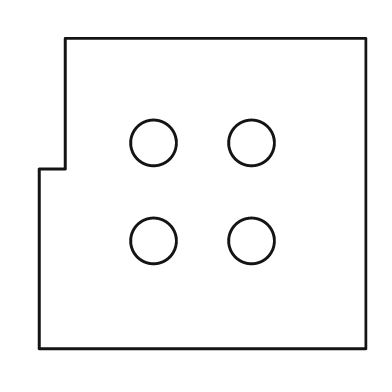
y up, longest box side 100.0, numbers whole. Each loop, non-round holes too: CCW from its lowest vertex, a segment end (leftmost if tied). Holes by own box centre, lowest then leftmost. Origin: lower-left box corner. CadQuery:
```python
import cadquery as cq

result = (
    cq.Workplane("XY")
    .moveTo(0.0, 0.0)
    .lineTo(100.0, 0.0)
    .lineTo(100.0, 95.0)
    .lineTo(8.0, 95.0)
    .lineTo(8.0, 55.0)
    .lineTo(0.0, 55.0)
    .close()
    .moveTo(35.0, 33.0)
    .circle(7.0)
    .moveTo(65.0, 33.0)
    .circle(7.0)
    .moveTo(35.0, 63.0)
    .circle(7.0)
    .moveTo(65.0, 63.0)
    .circle(7.0)
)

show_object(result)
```